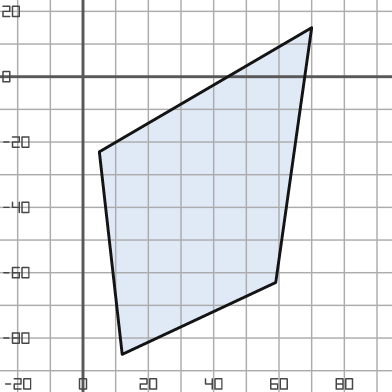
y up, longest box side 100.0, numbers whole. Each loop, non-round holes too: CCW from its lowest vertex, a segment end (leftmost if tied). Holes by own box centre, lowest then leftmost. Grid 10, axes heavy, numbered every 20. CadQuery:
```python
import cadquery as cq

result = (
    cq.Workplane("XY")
    .moveTo(12.0, -85.0)
    .lineTo(59.0, -63.0)
    .lineTo(70.0, 15.0)
    .lineTo(5.0, -23.0)
    .close()
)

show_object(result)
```